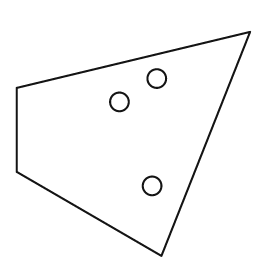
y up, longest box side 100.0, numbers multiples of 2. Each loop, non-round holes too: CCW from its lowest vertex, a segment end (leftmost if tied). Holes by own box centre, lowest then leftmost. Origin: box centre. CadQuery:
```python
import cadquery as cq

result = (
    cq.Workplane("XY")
    .moveTo(12.0, -48.0)
    .lineTo(50.0, 48.0)
    .lineTo(-50.0, 24.0)
    .lineTo(-50.0, -12.0)
    .close()
    .moveTo(8.0, -18.0)
    .circle(4.0)
    .moveTo(-6.0, 18.0)
    .circle(4.0)
    .moveTo(10.0, 28.0)
    .circle(4.0)
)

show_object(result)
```